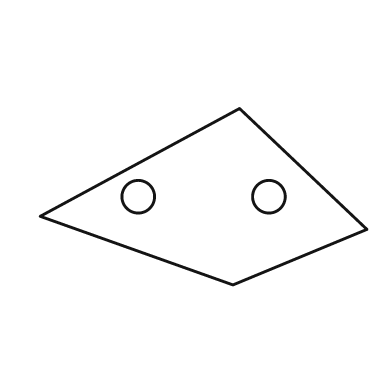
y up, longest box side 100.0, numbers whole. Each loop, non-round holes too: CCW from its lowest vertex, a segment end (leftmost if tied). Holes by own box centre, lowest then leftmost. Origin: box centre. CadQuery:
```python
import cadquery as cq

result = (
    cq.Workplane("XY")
    .moveTo(9.0, -27.0)
    .lineTo(50.0, -10.0)
    .lineTo(11.0, 27.0)
    .lineTo(-50.0, -6.0)
    .close()
    .moveTo(-20.0, 0.0)
    .circle(5.0)
    .moveTo(20.0, 0.0)
    .circle(5.0)
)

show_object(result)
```